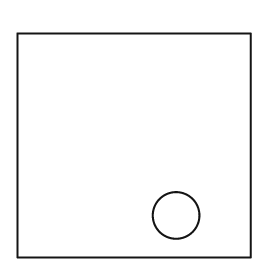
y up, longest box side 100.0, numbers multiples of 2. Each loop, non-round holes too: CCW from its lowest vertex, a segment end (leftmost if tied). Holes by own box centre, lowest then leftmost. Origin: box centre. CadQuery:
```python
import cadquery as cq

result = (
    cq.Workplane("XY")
    .moveTo(-50.0, -48.0)
    .lineTo(50.0, -48.0)
    .lineTo(50.0, 48.0)
    .lineTo(-50.0, 48.0)
    .close()
    .moveTo(18.0, -30.0)
    .circle(10.0)
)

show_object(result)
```